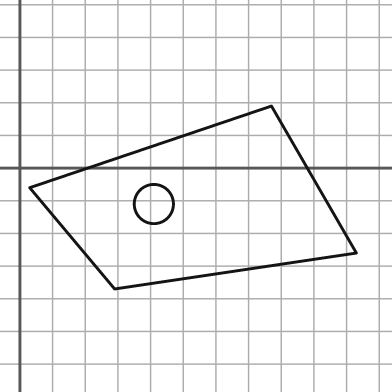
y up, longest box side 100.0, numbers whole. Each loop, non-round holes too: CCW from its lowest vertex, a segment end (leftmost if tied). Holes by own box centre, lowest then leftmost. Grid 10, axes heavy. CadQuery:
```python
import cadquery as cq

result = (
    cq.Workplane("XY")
    .moveTo(29.0, -37.0)
    .lineTo(103.0, -26.0)
    .lineTo(77.0, 19.0)
    .lineTo(3.0, -6.0)
    .close()
    .moveTo(41.0, -11.0)
    .circle(6.0)
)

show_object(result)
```